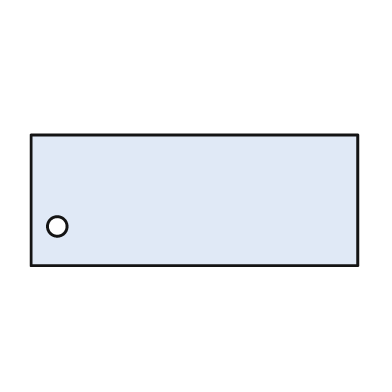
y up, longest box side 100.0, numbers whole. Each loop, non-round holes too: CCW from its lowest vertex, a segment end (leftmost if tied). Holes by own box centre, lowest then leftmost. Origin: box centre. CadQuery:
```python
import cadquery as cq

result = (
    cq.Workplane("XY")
    .moveTo(-50.0, -20.0)
    .lineTo(50.0, -20.0)
    .lineTo(50.0, 20.0)
    .lineTo(-50.0, 20.0)
    .close()
    .moveTo(-42.0, -8.0)
    .circle(3.0)
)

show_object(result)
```